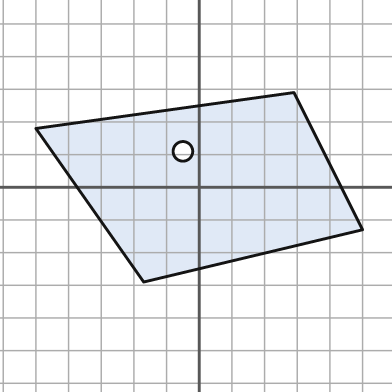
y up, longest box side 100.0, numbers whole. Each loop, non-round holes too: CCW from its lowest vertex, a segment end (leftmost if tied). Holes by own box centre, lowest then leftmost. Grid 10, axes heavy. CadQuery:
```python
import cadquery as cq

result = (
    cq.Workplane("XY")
    .moveTo(-17.0, -29.0)
    .lineTo(50.0, -13.0)
    .lineTo(29.0, 29.0)
    .lineTo(-50.0, 18.0)
    .close()
    .moveTo(-5.0, 11.0)
    .circle(3.0)
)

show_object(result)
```